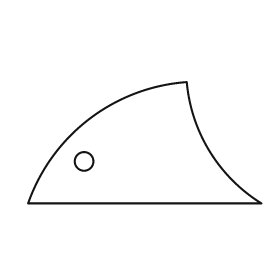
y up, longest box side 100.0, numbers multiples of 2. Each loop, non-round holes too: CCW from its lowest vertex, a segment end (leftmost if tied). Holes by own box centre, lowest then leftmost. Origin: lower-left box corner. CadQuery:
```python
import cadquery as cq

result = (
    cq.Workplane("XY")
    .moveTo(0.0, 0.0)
    .lineTo(100.0, 0.0)
    .threePointArc((78.0, 22.0), (68.0, 52.0))
    .threePointArc((26.0, 36.0), (0.0, 0.0))
    .close()
    .moveTo(24.0, 18.0)
    .circle(4.0)
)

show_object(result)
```